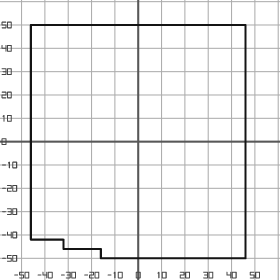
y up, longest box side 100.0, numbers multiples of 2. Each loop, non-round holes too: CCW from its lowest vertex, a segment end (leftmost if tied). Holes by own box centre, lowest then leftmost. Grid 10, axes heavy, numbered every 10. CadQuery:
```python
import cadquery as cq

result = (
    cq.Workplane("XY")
    .moveTo(-16.0, -50.0)
    .lineTo(46.0, -50.0)
    .lineTo(46.0, 50.0)
    .lineTo(-46.0, 50.0)
    .lineTo(-46.0, -42.0)
    .lineTo(-32.0, -42.0)
    .lineTo(-32.0, -46.0)
    .lineTo(-16.0, -46.0)
    .close()
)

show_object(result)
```